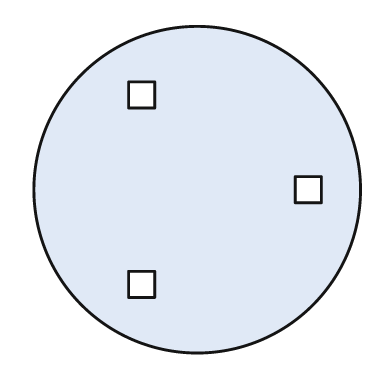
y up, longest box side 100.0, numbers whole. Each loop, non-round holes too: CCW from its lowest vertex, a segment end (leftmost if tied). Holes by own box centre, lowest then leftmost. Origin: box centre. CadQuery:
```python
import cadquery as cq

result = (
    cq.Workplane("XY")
    .moveTo(0.0, 0.0)
    .circle(50.0)
    .moveTo(-21.0, -33.0)
    .lineTo(-13.0, -33.0)
    .lineTo(-13.0, -25.0)
    .lineTo(-21.0, -25.0)
    .close()
    .moveTo(30.0, -4.0)
    .lineTo(38.0, -4.0)
    .lineTo(38.0, 4.0)
    .lineTo(30.0, 4.0)
    .close()
    .moveTo(-21.0, 25.0)
    .lineTo(-13.0, 25.0)
    .lineTo(-13.0, 33.0)
    .lineTo(-21.0, 33.0)
    .close()
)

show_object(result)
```